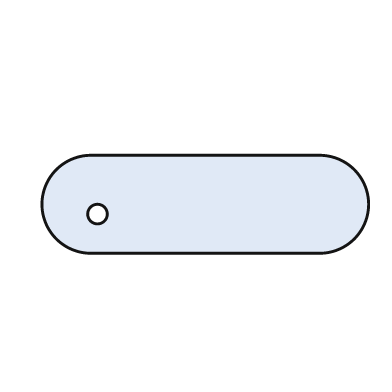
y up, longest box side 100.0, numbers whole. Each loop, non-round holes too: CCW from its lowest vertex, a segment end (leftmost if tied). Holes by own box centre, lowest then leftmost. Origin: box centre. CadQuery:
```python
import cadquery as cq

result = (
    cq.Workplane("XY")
    .moveTo(-35.0, -15.0)
    .lineTo(35.0, -15.0)
    .threePointArc((50.0, 0.0), (35.0, 15.0))
    .lineTo(-35.0, 15.0)
    .threePointArc((-50.0, 0.0), (-35.0, -15.0))
    .close()
    .moveTo(-33.0, -3.0)
    .circle(3.0)
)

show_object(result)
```